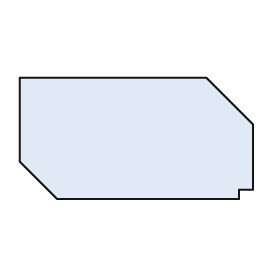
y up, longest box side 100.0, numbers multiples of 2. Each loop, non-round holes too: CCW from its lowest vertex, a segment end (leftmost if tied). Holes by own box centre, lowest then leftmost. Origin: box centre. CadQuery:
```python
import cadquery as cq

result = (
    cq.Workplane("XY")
    .moveTo(-34.0, -26.0)
    .lineTo(44.0, -26.0)
    .lineTo(44.0, -22.0)
    .lineTo(50.0, -22.0)
    .lineTo(50.0, 6.0)
    .lineTo(30.0, 26.0)
    .lineTo(-50.0, 26.0)
    .lineTo(-50.0, -10.0)
    .close()
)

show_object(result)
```